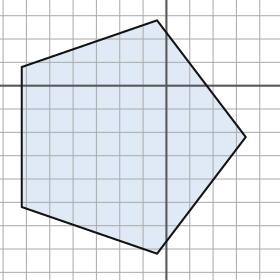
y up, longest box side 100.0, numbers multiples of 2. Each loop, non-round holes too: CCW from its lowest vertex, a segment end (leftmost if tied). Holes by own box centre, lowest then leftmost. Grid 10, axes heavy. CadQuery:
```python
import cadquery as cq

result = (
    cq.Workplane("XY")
    .moveTo(-4.0, -72.0)
    .lineTo(34.0, -22.0)
    .lineTo(-4.0, 28.0)
    .lineTo(-62.0, 8.0)
    .lineTo(-62.0, -52.0)
    .close()
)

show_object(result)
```